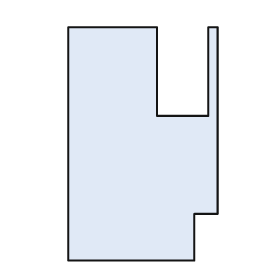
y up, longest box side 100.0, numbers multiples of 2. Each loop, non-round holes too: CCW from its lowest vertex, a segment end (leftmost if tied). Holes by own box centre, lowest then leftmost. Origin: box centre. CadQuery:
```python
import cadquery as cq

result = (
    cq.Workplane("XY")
    .moveTo(-32.0, -50.0)
    .lineTo(22.0, -50.0)
    .lineTo(22.0, -30.0)
    .lineTo(32.0, -30.0)
    .lineTo(32.0, 50.0)
    .lineTo(28.0, 50.0)
    .lineTo(28.0, 12.0)
    .lineTo(6.0, 12.0)
    .lineTo(6.0, 50.0)
    .lineTo(-32.0, 50.0)
    .close()
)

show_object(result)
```